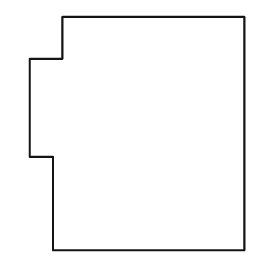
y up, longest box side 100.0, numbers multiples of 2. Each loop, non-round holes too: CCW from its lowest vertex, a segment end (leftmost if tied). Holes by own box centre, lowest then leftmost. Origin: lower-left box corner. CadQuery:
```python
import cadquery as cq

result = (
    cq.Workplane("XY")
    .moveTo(10.0, 0.0)
    .lineTo(92.0, 0.0)
    .lineTo(92.0, 100.0)
    .lineTo(14.0, 100.0)
    .lineTo(14.0, 82.0)
    .lineTo(0.0, 82.0)
    .lineTo(0.0, 40.0)
    .lineTo(10.0, 40.0)
    .close()
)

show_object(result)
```